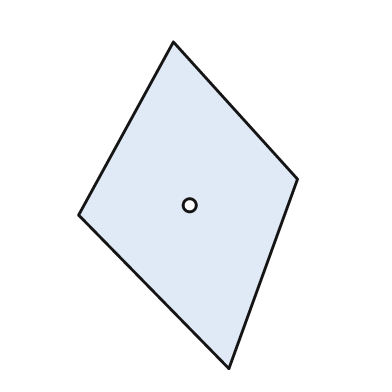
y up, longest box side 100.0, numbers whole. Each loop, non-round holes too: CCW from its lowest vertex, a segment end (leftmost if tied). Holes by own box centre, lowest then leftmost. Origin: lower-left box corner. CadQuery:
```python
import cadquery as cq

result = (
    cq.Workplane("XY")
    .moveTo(46.0, 0.0)
    .lineTo(67.0, 58.0)
    .lineTo(29.0, 100.0)
    .lineTo(0.0, 47.0)
    .close()
    .moveTo(34.0, 50.0)
    .circle(2.0)
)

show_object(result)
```